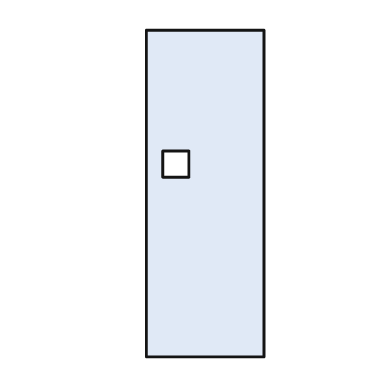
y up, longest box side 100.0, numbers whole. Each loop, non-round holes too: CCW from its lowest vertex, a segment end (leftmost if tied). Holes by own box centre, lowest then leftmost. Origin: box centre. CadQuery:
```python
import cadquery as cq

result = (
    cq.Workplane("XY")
    .moveTo(-18.0, -50.0)
    .lineTo(18.0, -50.0)
    .lineTo(18.0, 50.0)
    .lineTo(-18.0, 50.0)
    .close()
    .moveTo(-13.0, 5.0)
    .lineTo(-5.0, 5.0)
    .lineTo(-5.0, 13.0)
    .lineTo(-13.0, 13.0)
    .close()
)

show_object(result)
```